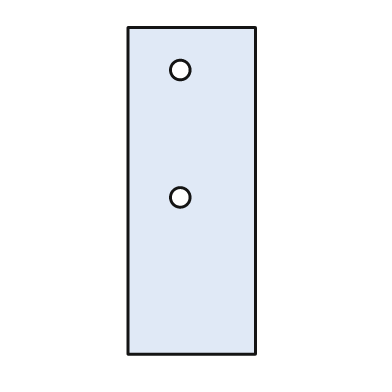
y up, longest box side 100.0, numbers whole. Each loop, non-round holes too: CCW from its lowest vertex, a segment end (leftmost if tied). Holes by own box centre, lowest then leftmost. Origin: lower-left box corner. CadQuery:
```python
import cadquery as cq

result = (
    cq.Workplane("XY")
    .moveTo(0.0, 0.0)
    .lineTo(39.0, 0.0)
    .lineTo(39.0, 100.0)
    .lineTo(0.0, 100.0)
    .close()
    .moveTo(16.0, 48.0)
    .circle(3.0)
    .moveTo(16.0, 87.0)
    .circle(3.0)
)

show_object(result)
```